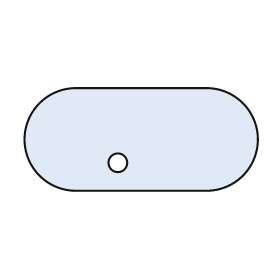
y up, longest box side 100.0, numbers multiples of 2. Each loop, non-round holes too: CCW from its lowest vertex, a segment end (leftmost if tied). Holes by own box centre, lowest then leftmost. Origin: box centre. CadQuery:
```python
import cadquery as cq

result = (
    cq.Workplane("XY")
    .moveTo(-28.0, -22.0)
    .lineTo(28.0, -22.0)
    .threePointArc((50.0, 0.0), (28.0, 22.0))
    .lineTo(-28.0, 22.0)
    .threePointArc((-50.0, 0.0), (-28.0, -22.0))
    .close()
    .moveTo(-10.0, -10.0)
    .circle(4.0)
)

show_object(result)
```